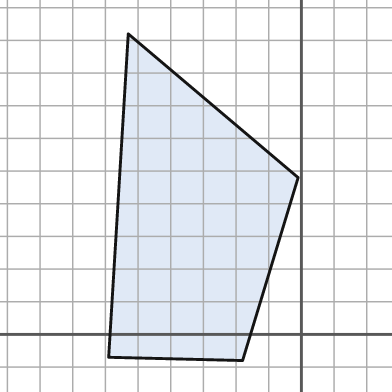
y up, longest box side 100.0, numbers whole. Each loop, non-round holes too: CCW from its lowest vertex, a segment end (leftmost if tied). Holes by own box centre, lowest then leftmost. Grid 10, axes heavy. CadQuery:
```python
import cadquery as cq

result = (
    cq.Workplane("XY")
    .moveTo(-18.0, -8.0)
    .lineTo(-1.0, 48.0)
    .lineTo(-53.0, 92.0)
    .lineTo(-59.0, -7.0)
    .close()
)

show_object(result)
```